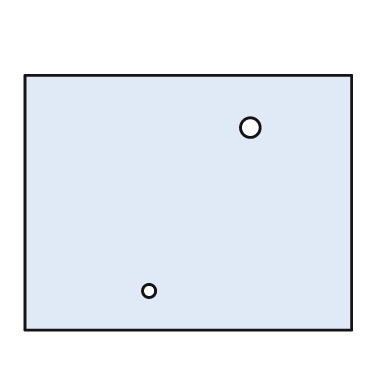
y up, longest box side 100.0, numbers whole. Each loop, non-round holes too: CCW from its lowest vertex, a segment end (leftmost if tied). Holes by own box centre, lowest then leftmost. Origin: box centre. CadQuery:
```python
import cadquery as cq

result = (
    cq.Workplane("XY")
    .moveTo(-50.0, -39.0)
    .lineTo(50.0, -39.0)
    .lineTo(50.0, 39.0)
    .lineTo(-50.0, 39.0)
    .close()
    .moveTo(-12.0, -27.0)
    .circle(2.0)
    .moveTo(19.0, 23.0)
    .circle(3.0)
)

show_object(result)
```